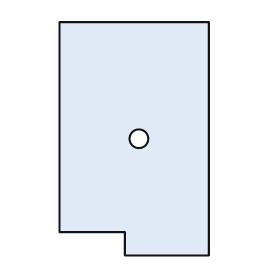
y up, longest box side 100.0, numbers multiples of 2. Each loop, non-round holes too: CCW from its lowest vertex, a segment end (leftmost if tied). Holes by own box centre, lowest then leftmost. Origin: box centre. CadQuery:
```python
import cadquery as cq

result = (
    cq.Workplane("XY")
    .moveTo(-4.0, -50.0)
    .lineTo(32.0, -50.0)
    .lineTo(32.0, 50.0)
    .lineTo(-32.0, 50.0)
    .lineTo(-32.0, -40.0)
    .lineTo(-4.0, -40.0)
    .close()
    .moveTo(2.0, 0.0)
    .circle(4.0)
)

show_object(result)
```